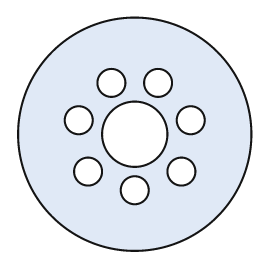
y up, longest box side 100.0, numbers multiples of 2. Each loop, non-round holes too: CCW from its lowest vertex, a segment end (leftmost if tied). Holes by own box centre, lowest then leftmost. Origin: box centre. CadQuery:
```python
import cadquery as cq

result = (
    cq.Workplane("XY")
    .moveTo(0.0, 0.0)
    .circle(50.0)
    .moveTo(0.0, -24.0)
    .circle(6.0)
    .moveTo(-20.0, -16.0)
    .circle(6.0)
    .moveTo(20.0, -16.0)
    .circle(6.0)
    .moveTo(0.0, 0.0)
    .circle(14.0)
    .moveTo(-24.0, 6.0)
    .circle(6.0)
    .moveTo(24.0, 6.0)
    .circle(6.0)
    .moveTo(-10.0, 22.0)
    .circle(6.0)
    .moveTo(10.0, 22.0)
    .circle(6.0)
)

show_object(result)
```